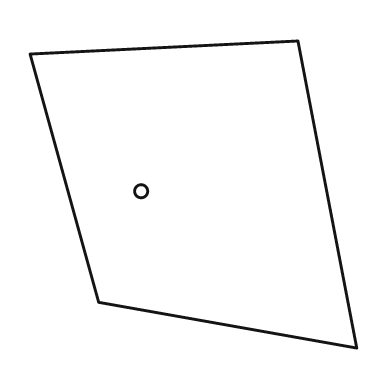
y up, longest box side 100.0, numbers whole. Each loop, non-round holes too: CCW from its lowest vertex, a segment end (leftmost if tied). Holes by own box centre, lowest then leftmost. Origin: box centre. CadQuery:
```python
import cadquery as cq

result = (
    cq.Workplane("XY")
    .moveTo(50.0, -47.0)
    .lineTo(32.0, 47.0)
    .lineTo(-50.0, 43.0)
    .lineTo(-29.0, -33.0)
    .close()
    .moveTo(-16.0, 1.0)
    .circle(2.0)
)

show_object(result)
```